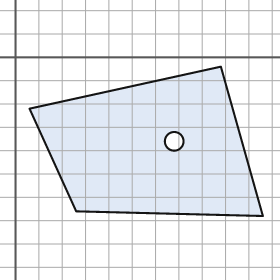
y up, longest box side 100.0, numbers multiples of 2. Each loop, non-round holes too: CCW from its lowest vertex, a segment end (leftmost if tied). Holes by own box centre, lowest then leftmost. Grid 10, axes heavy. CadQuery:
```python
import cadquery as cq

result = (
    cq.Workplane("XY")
    .moveTo(106.0, -68.0)
    .lineTo(88.0, -4.0)
    .lineTo(6.0, -22.0)
    .lineTo(26.0, -66.0)
    .close()
    .moveTo(68.0, -36.0)
    .circle(4.0)
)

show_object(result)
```